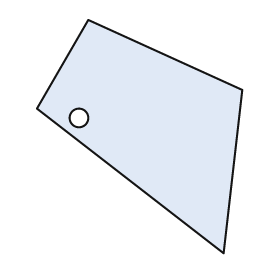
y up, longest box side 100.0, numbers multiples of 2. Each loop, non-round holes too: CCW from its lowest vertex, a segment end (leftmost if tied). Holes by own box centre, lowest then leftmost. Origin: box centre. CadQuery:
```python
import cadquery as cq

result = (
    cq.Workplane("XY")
    .moveTo(36.0, -50.0)
    .lineTo(44.0, 20.0)
    .lineTo(-22.0, 50.0)
    .lineTo(-44.0, 12.0)
    .close()
    .moveTo(-26.0, 8.0)
    .circle(4.0)
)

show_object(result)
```